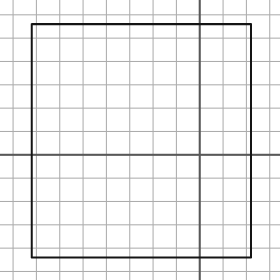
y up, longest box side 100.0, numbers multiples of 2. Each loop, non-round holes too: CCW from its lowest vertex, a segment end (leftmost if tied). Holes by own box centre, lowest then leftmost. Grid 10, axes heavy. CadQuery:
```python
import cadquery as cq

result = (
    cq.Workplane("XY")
    .moveTo(-72.0, -44.0)
    .lineTo(22.0, -44.0)
    .lineTo(22.0, 56.0)
    .lineTo(-72.0, 56.0)
    .close()
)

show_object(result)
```